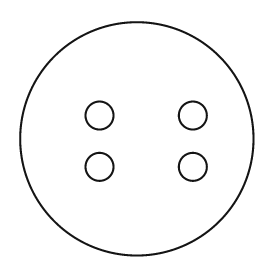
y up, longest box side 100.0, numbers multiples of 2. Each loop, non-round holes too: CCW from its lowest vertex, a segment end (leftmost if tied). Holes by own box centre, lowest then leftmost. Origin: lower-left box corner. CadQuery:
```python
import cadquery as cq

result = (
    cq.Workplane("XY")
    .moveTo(50.0, 50.0)
    .circle(50.0)
    .moveTo(34.0, 38.0)
    .circle(6.0)
    .moveTo(74.0, 38.0)
    .circle(6.0)
    .moveTo(34.0, 60.0)
    .circle(6.0)
    .moveTo(74.0, 60.0)
    .circle(6.0)
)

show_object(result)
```